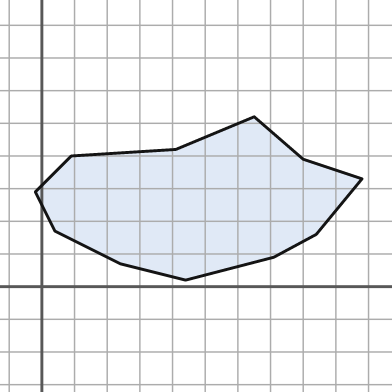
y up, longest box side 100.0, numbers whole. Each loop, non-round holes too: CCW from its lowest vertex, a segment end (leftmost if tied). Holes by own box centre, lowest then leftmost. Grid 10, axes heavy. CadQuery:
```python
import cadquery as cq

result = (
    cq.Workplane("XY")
    .moveTo(44.0, 2.0)
    .lineTo(71.0, 9.0)
    .lineTo(84.0, 16.0)
    .lineTo(98.0, 33.0)
    .lineTo(80.0, 39.0)
    .lineTo(65.0, 52.0)
    .lineTo(41.0, 42.0)
    .lineTo(9.0, 40.0)
    .lineTo(-2.0, 29.0)
    .lineTo(4.0, 17.0)
    .lineTo(24.0, 7.0)
    .close()
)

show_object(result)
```